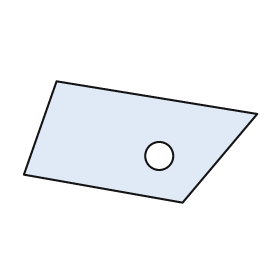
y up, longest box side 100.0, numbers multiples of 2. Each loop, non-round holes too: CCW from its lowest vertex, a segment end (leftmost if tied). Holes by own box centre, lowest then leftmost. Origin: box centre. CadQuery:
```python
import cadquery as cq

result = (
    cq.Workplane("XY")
    .moveTo(18.0, -26.0)
    .lineTo(50.0, 12.0)
    .lineTo(-36.0, 26.0)
    .lineTo(-50.0, -14.0)
    .close()
    .moveTo(8.0, -6.0)
    .circle(6.0)
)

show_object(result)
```